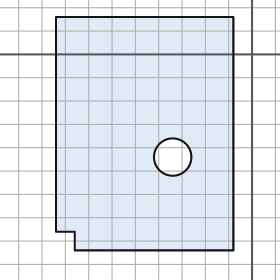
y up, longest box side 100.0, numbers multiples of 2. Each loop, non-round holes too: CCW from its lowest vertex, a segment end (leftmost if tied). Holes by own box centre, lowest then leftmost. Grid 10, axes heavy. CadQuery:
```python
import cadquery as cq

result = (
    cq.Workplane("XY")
    .moveTo(-76.0, -84.0)
    .lineTo(-8.0, -84.0)
    .lineTo(-8.0, 16.0)
    .lineTo(-84.0, 16.0)
    .lineTo(-84.0, -76.0)
    .lineTo(-76.0, -76.0)
    .close()
    .moveTo(-34.0, -44.0)
    .circle(8.0)
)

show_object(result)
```